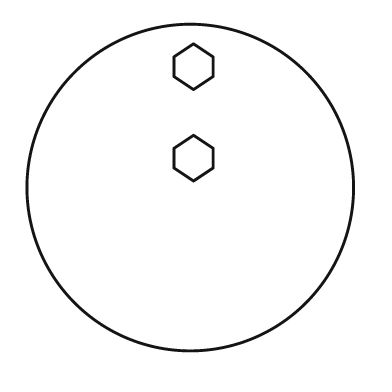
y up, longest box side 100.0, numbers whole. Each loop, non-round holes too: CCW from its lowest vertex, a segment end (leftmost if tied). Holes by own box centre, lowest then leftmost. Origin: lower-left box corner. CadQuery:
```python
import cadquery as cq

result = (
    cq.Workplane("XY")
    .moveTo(50.0, 50.0)
    .circle(50.0)
    .moveTo(51.0, 52.0)
    .lineTo(57.0, 56.0)
    .lineTo(57.0, 62.0)
    .lineTo(51.0, 66.0)
    .lineTo(45.0, 62.0)
    .lineTo(45.0, 56.0)
    .close()
    .moveTo(51.0, 80.0)
    .lineTo(57.0, 84.0)
    .lineTo(57.0, 90.0)
    .lineTo(51.0, 94.0)
    .lineTo(45.0, 90.0)
    .lineTo(45.0, 84.0)
    .close()
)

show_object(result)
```